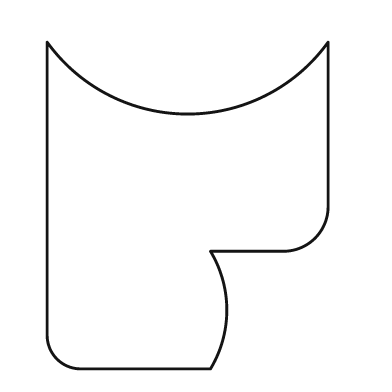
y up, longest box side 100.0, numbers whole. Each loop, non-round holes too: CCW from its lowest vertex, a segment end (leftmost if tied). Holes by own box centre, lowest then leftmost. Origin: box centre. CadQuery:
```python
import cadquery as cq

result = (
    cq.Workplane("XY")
    .moveTo(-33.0, -50.0)
    .lineTo(7.0, -50.0)
    .threePointArc((12.0, -32.0), (7.0, -14.0))
    .lineTo(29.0, -14.0)
    .threePointArc((39.0, -10.0), (43.0, 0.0))
    .lineTo(43.0, 50.0)
    .threePointArc((0.0, 28.0), (-43.0, 50.0))
    .lineTo(-43.0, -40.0)
    .threePointArc((-40.0, -47.0), (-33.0, -50.0))
    .close()
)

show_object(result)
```